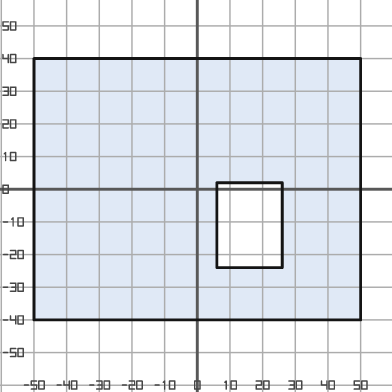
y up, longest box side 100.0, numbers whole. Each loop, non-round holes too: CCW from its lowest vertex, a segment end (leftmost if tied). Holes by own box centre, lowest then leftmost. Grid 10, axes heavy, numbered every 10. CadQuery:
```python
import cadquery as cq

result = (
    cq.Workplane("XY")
    .moveTo(-50.0, -40.0)
    .lineTo(50.0, -40.0)
    .lineTo(50.0, 40.0)
    .lineTo(-50.0, 40.0)
    .close()
    .moveTo(6.0, -24.0)
    .lineTo(26.0, -24.0)
    .lineTo(26.0, 2.0)
    .lineTo(6.0, 2.0)
    .close()
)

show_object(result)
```